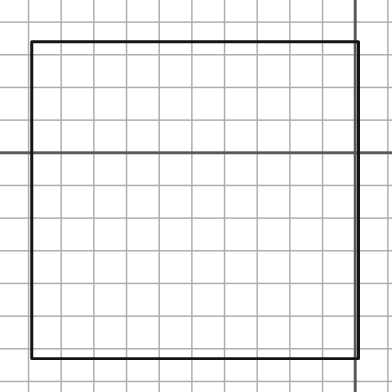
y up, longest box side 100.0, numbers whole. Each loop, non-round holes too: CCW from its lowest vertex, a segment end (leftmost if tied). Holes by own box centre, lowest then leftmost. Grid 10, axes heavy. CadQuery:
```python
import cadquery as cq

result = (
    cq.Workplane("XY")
    .moveTo(-99.0, -63.0)
    .lineTo(1.0, -63.0)
    .lineTo(1.0, 34.0)
    .lineTo(-99.0, 34.0)
    .close()
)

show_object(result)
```